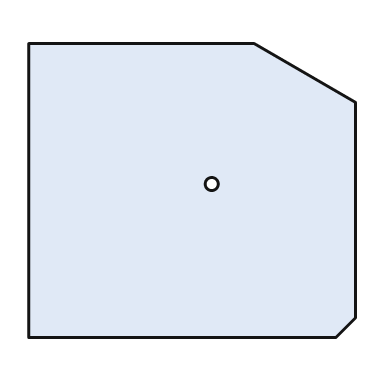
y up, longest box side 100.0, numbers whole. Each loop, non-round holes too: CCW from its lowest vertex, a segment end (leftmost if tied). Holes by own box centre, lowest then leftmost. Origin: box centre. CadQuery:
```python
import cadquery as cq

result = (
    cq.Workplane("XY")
    .moveTo(-50.0, -45.0)
    .lineTo(44.0, -45.0)
    .lineTo(50.0, -39.0)
    .lineTo(50.0, 27.0)
    .lineTo(19.0, 45.0)
    .lineTo(-50.0, 45.0)
    .close()
    .moveTo(6.0, 2.0)
    .circle(2.0)
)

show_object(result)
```